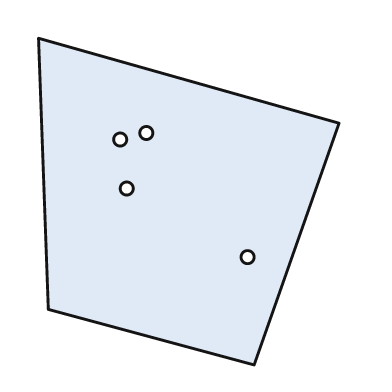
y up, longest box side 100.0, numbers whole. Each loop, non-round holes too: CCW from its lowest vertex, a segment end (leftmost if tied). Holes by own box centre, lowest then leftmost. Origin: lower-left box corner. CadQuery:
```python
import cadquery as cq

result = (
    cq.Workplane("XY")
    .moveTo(66.0, 0.0)
    .lineTo(92.0, 74.0)
    .lineTo(0.0, 100.0)
    .lineTo(3.0, 17.0)
    .close()
    .moveTo(64.0, 33.0)
    .circle(2.0)
    .moveTo(27.0, 54.0)
    .circle(2.0)
    .moveTo(25.0, 69.0)
    .circle(2.0)
    .moveTo(33.0, 71.0)
    .circle(2.0)
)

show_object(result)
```